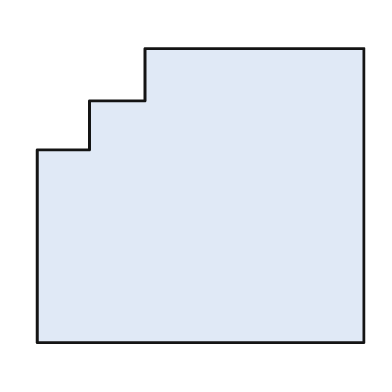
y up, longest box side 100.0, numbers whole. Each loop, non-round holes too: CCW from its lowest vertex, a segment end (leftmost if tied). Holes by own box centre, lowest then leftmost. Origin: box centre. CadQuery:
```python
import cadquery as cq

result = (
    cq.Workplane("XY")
    .moveTo(-50.0, -45.0)
    .lineTo(50.0, -45.0)
    .lineTo(50.0, 45.0)
    .lineTo(-17.0, 45.0)
    .lineTo(-17.0, 29.0)
    .lineTo(-34.0, 29.0)
    .lineTo(-34.0, 14.0)
    .lineTo(-50.0, 14.0)
    .close()
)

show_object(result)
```